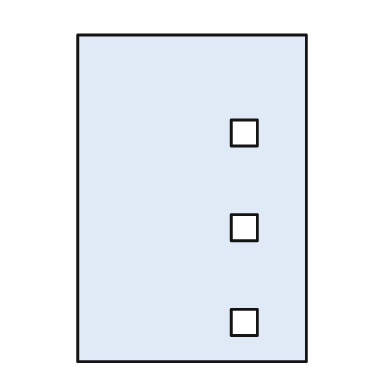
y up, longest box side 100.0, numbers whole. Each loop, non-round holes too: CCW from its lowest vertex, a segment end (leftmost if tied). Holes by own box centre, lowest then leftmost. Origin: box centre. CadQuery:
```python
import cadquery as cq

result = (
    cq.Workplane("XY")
    .moveTo(-35.0, -50.0)
    .lineTo(35.0, -50.0)
    .lineTo(35.0, 50.0)
    .lineTo(-35.0, 50.0)
    .close()
    .moveTo(12.0, -42.0)
    .lineTo(20.0, -42.0)
    .lineTo(20.0, -34.0)
    .lineTo(12.0, -34.0)
    .close()
    .moveTo(12.0, -13.0)
    .lineTo(20.0, -13.0)
    .lineTo(20.0, -5.0)
    .lineTo(12.0, -5.0)
    .close()
    .moveTo(12.0, 16.0)
    .lineTo(20.0, 16.0)
    .lineTo(20.0, 24.0)
    .lineTo(12.0, 24.0)
    .close()
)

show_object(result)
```